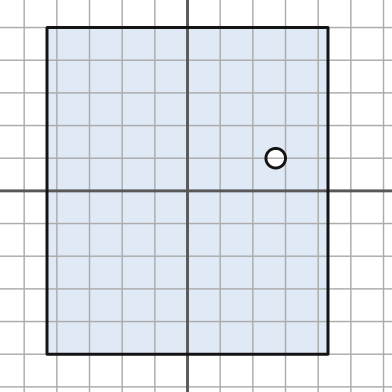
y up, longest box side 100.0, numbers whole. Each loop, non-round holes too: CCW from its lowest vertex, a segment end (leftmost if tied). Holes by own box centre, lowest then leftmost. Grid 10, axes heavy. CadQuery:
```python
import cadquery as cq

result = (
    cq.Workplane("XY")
    .moveTo(-43.0, -50.0)
    .lineTo(43.0, -50.0)
    .lineTo(43.0, 50.0)
    .lineTo(-43.0, 50.0)
    .close()
    .moveTo(27.0, 10.0)
    .circle(3.0)
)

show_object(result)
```